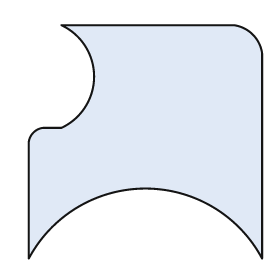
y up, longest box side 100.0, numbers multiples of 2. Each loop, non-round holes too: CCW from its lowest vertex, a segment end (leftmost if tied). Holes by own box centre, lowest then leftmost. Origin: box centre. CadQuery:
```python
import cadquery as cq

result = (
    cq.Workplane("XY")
    .moveTo(-50.0, -50.0)
    .threePointArc((0.0, -20.0), (50.0, -50.0))
    .lineTo(50.0, 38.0)
    .threePointArc((46.0, 46.0), (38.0, 50.0))
    .lineTo(-36.0, 50.0)
    .threePointArc((-22.0, 28.0), (-36.0, 6.0))
    .lineTo(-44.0, 6.0)
    .threePointArc((-48.0, 4.0), (-50.0, 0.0))
    .close()
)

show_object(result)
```